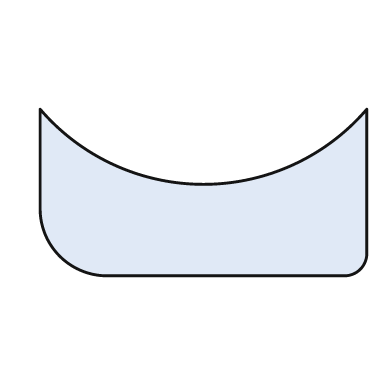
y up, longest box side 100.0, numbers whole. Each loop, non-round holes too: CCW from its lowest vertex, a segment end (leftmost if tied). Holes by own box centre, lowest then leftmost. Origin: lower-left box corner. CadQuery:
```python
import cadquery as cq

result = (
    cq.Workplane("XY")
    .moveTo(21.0, 0.0)
    .lineTo(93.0, 0.0)
    .threePointArc((98.0, 2.0), (100.0, 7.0))
    .lineTo(100.0, 51.0)
    .threePointArc((50.0, 28.0), (0.0, 51.0))
    .lineTo(0.0, 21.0)
    .threePointArc((6.0, 6.0), (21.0, 0.0))
    .close()
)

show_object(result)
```